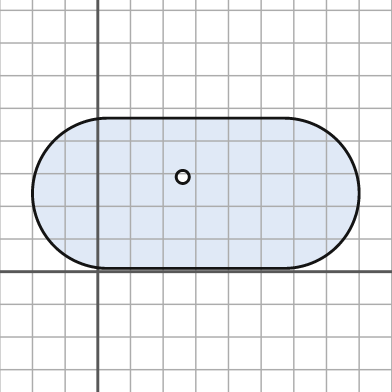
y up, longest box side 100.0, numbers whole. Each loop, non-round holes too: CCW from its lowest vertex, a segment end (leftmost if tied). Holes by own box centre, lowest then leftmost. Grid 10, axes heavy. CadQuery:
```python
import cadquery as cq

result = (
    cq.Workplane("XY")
    .moveTo(3.0, 1.0)
    .lineTo(57.0, 1.0)
    .threePointArc((80.0, 24.0), (57.0, 47.0))
    .lineTo(3.0, 47.0)
    .threePointArc((-20.0, 24.0), (3.0, 1.0))
    .close()
    .moveTo(26.0, 29.0)
    .circle(2.0)
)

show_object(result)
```